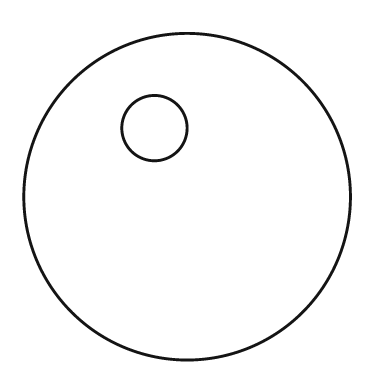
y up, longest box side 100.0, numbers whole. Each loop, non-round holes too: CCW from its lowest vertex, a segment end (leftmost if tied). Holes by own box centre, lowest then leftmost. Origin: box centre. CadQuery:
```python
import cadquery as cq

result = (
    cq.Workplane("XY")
    .moveTo(0.0, 0.0)
    .circle(50.0)
    .moveTo(-10.0, 21.0)
    .circle(10.0)
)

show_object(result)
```